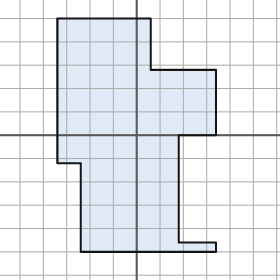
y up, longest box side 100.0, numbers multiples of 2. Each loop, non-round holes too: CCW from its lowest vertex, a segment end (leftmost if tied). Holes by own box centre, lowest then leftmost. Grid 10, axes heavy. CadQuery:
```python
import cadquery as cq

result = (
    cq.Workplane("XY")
    .moveTo(-24.0, -50.0)
    .lineTo(34.0, -50.0)
    .lineTo(34.0, -46.0)
    .lineTo(18.0, -46.0)
    .lineTo(18.0, 0.0)
    .lineTo(34.0, 0.0)
    .lineTo(34.0, 28.0)
    .lineTo(6.0, 28.0)
    .lineTo(6.0, 50.0)
    .lineTo(-34.0, 50.0)
    .lineTo(-34.0, -12.0)
    .lineTo(-24.0, -12.0)
    .close()
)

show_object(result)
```